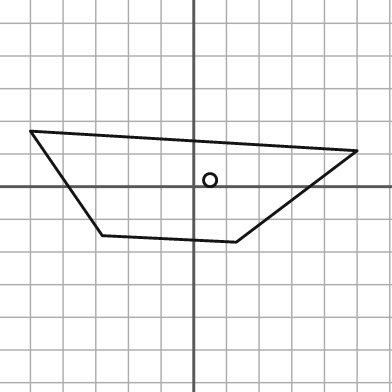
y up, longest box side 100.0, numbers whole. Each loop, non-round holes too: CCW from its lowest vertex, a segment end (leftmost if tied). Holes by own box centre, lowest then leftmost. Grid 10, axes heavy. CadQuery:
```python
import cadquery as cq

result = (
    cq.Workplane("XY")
    .moveTo(13.0, -17.0)
    .lineTo(50.0, 11.0)
    .lineTo(-50.0, 17.0)
    .lineTo(-28.0, -15.0)
    .close()
    .moveTo(5.0, 2.0)
    .circle(2.0)
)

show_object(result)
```